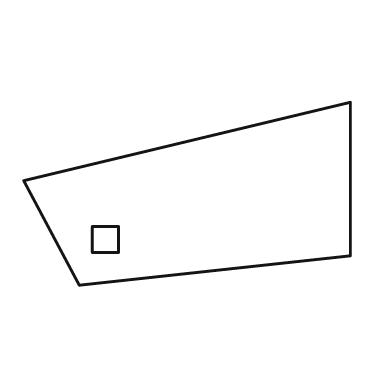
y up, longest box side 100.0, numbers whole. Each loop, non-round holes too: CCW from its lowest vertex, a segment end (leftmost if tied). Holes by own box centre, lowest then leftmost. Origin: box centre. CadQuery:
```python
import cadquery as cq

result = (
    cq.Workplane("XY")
    .moveTo(-33.0, -28.0)
    .lineTo(50.0, -19.0)
    .lineTo(50.0, 28.0)
    .lineTo(-50.0, 4.0)
    .close()
    .moveTo(-29.0, -18.0)
    .lineTo(-21.0, -18.0)
    .lineTo(-21.0, -10.0)
    .lineTo(-29.0, -10.0)
    .close()
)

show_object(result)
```